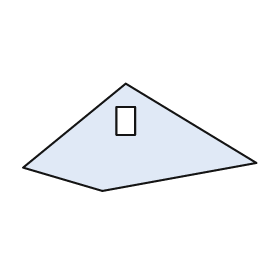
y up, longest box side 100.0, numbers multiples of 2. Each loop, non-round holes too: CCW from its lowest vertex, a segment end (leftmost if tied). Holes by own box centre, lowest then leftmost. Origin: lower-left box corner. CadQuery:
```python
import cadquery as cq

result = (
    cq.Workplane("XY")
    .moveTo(34.0, 0.0)
    .lineTo(100.0, 12.0)
    .lineTo(44.0, 46.0)
    .lineTo(0.0, 10.0)
    .close()
    .moveTo(40.0, 24.0)
    .lineTo(48.0, 24.0)
    .lineTo(48.0, 36.0)
    .lineTo(40.0, 36.0)
    .close()
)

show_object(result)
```